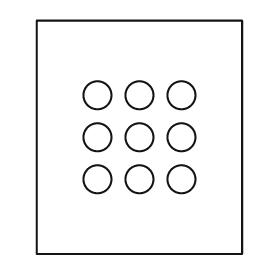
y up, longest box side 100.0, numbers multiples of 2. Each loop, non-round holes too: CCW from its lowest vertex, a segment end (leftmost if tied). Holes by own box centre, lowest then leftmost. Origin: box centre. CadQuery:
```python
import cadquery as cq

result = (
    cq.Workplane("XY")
    .moveTo(-44.0, -50.0)
    .lineTo(44.0, -50.0)
    .lineTo(44.0, 50.0)
    .lineTo(-44.0, 50.0)
    .close()
    .moveTo(-18.0, -18.0)
    .circle(6.0)
    .moveTo(0.0, -18.0)
    .circle(6.0)
    .moveTo(18.0, -18.0)
    .circle(6.0)
    .moveTo(-18.0, 0.0)
    .circle(6.0)
    .moveTo(0.0, 0.0)
    .circle(6.0)
    .moveTo(18.0, 0.0)
    .circle(6.0)
    .moveTo(-18.0, 18.0)
    .circle(6.0)
    .moveTo(0.0, 18.0)
    .circle(6.0)
    .moveTo(18.0, 18.0)
    .circle(6.0)
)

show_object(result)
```